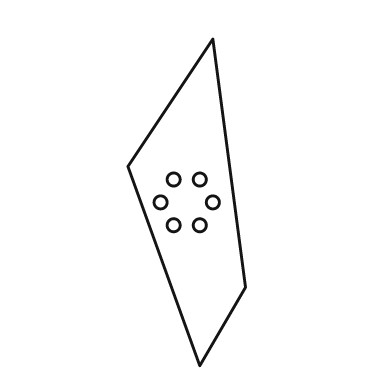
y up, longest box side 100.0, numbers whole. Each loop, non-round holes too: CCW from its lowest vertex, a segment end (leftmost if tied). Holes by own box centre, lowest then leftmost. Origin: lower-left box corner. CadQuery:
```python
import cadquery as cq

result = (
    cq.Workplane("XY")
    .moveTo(22.0, 0.0)
    .lineTo(36.0, 24.0)
    .lineTo(26.0, 100.0)
    .lineTo(0.0, 61.0)
    .close()
    .moveTo(14.0, 43.0)
    .circle(2.0)
    .moveTo(22.0, 43.0)
    .circle(2.0)
    .moveTo(10.0, 50.0)
    .circle(2.0)
    .moveTo(26.0, 50.0)
    .circle(2.0)
    .moveTo(14.0, 57.0)
    .circle(2.0)
    .moveTo(22.0, 57.0)
    .circle(2.0)
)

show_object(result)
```